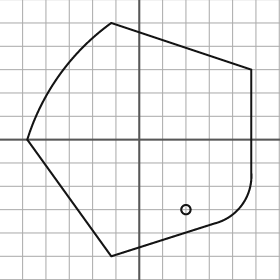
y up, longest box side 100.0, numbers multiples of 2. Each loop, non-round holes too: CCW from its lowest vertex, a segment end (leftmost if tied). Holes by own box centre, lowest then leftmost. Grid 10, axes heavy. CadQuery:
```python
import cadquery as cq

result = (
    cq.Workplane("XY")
    .moveTo(-12.0, -50.0)
    .lineTo(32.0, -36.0)
    .threePointArc((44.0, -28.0), (48.0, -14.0))
    .lineTo(48.0, 30.0)
    .lineTo(-12.0, 50.0)
    .threePointArc((-34.0, 28.0), (-48.0, 0.0))
    .close()
    .moveTo(20.0, -30.0)
    .circle(2.0)
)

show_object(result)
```